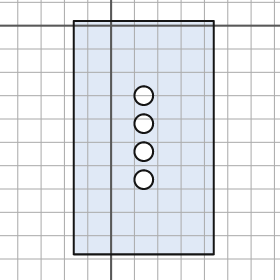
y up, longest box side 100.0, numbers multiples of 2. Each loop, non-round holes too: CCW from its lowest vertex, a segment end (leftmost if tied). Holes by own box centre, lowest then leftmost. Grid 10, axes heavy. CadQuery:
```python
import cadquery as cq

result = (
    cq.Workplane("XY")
    .moveTo(-16.0, -98.0)
    .lineTo(44.0, -98.0)
    .lineTo(44.0, 2.0)
    .lineTo(-16.0, 2.0)
    .close()
    .moveTo(14.0, -66.0)
    .circle(4.0)
    .moveTo(14.0, -54.0)
    .circle(4.0)
    .moveTo(14.0, -42.0)
    .circle(4.0)
    .moveTo(14.0, -30.0)
    .circle(4.0)
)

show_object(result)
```